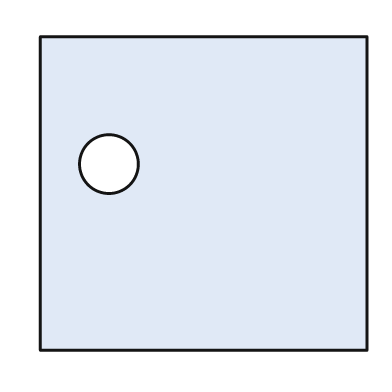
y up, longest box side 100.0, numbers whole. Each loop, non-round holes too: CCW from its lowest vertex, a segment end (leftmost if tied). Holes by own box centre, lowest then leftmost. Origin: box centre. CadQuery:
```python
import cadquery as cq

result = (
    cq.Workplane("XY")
    .moveTo(-50.0, -48.0)
    .lineTo(50.0, -48.0)
    .lineTo(50.0, 48.0)
    .lineTo(-50.0, 48.0)
    .close()
    .moveTo(-29.0, 9.0)
    .circle(9.0)
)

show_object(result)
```